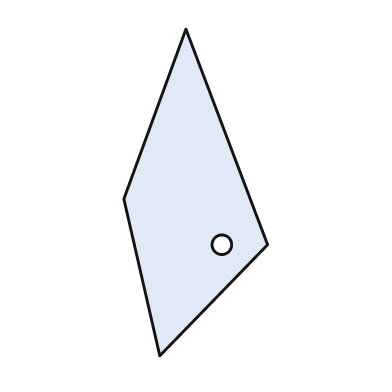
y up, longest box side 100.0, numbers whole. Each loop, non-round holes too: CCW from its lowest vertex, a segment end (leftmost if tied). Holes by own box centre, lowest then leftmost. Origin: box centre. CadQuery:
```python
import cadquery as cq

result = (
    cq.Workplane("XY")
    .moveTo(-11.0, -50.0)
    .lineTo(22.0, -16.0)
    .lineTo(-3.0, 50.0)
    .lineTo(-22.0, -2.0)
    .close()
    .moveTo(8.0, -16.0)
    .circle(3.0)
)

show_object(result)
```